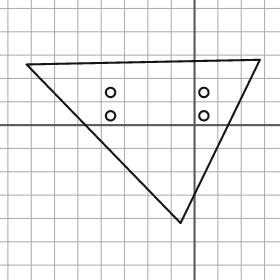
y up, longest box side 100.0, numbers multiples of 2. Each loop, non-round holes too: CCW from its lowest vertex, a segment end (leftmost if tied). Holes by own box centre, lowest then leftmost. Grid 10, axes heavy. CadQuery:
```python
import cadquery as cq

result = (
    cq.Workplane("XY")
    .moveTo(-6.0, -42.0)
    .lineTo(28.0, 28.0)
    .lineTo(-72.0, 26.0)
    .close()
    .moveTo(-36.0, 4.0)
    .circle(2.0)
    .moveTo(4.0, 4.0)
    .circle(2.0)
    .moveTo(-36.0, 14.0)
    .circle(2.0)
    .moveTo(4.0, 14.0)
    .circle(2.0)
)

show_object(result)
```